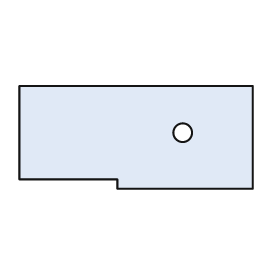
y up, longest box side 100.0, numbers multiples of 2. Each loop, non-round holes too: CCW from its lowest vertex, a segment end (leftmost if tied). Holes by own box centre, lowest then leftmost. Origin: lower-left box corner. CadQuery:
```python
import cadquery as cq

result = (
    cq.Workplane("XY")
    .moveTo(42.0, 0.0)
    .lineTo(100.0, 0.0)
    .lineTo(100.0, 44.0)
    .lineTo(0.0, 44.0)
    .lineTo(0.0, 4.0)
    .lineTo(42.0, 4.0)
    .close()
    .moveTo(70.0, 24.0)
    .circle(4.0)
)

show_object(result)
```